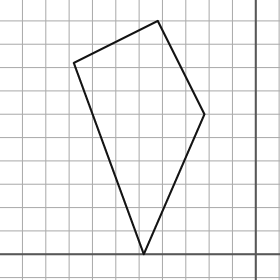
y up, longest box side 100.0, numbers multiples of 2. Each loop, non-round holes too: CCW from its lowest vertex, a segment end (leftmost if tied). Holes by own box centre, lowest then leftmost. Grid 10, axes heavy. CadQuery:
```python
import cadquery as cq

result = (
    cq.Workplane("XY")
    .moveTo(-48.0, 0.0)
    .lineTo(-22.0, 60.0)
    .lineTo(-42.0, 100.0)
    .lineTo(-78.0, 82.0)
    .close()
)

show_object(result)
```